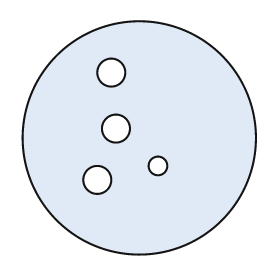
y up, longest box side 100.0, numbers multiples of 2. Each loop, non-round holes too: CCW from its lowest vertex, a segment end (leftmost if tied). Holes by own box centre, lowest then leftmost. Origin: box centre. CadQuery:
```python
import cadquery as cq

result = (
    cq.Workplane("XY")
    .moveTo(0.0, 0.0)
    .circle(50.0)
    .moveTo(-18.0, -18.0)
    .circle(6.0)
    .moveTo(8.0, -12.0)
    .circle(4.0)
    .moveTo(-10.0, 4.0)
    .circle(6.0)
    .moveTo(-12.0, 28.0)
    .circle(6.0)
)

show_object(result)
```